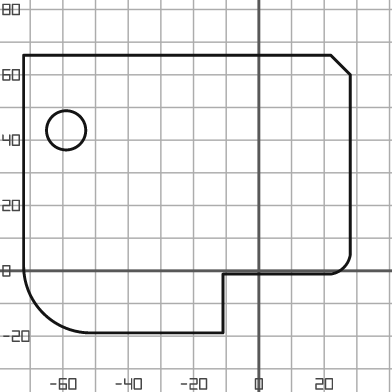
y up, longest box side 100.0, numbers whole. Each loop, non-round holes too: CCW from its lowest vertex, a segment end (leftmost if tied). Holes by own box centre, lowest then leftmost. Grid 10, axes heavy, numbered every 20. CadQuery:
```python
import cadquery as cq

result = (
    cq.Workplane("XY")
    .moveTo(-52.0, -19.0)
    .lineTo(-11.0, -19.0)
    .lineTo(-11.0, -1.0)
    .lineTo(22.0, -1.0)
    .threePointArc((26.0, 1.0), (28.0, 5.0))
    .lineTo(28.0, 60.0)
    .lineTo(22.0, 66.0)
    .lineTo(-72.0, 66.0)
    .lineTo(-72.0, 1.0)
    .threePointArc((-66.0, -13.0), (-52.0, -19.0))
    .close()
    .moveTo(-59.0, 43.0)
    .circle(6.0)
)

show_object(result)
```